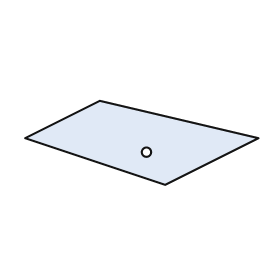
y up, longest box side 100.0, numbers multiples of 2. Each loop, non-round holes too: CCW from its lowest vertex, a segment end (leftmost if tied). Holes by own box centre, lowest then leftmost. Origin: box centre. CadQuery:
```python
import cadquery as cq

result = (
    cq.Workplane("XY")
    .moveTo(10.0, -18.0)
    .lineTo(50.0, 2.0)
    .lineTo(-18.0, 18.0)
    .lineTo(-50.0, 2.0)
    .close()
    .moveTo(2.0, -4.0)
    .circle(2.0)
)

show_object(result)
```